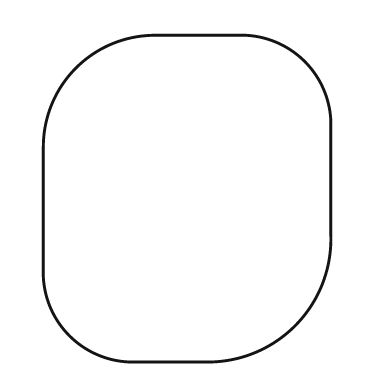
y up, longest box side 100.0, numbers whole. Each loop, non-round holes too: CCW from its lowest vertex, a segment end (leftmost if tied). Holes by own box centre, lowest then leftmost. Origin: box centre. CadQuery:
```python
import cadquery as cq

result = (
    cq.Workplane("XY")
    .moveTo(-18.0, -50.0)
    .lineTo(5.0, -50.0)
    .threePointArc((33.0, -39.0), (44.0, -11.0))
    .lineTo(44.0, 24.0)
    .threePointArc((36.0, 42.0), (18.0, 50.0))
    .lineTo(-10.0, 50.0)
    .threePointArc((-34.0, 40.0), (-44.0, 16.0))
    .lineTo(-44.0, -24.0)
    .threePointArc((-36.0, -42.0), (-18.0, -50.0))
    .close()
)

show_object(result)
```